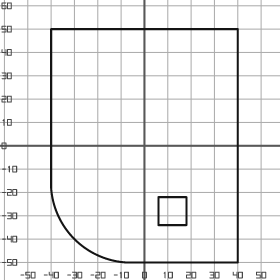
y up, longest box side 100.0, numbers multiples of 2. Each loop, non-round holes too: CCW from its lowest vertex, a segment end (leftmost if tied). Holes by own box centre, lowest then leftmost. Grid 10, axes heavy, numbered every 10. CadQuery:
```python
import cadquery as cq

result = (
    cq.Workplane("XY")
    .moveTo(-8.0, -50.0)
    .lineTo(40.0, -50.0)
    .lineTo(40.0, 50.0)
    .lineTo(-40.0, 50.0)
    .lineTo(-40.0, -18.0)
    .threePointArc((-30.0, -40.0), (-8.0, -50.0))
    .close()
    .moveTo(6.0, -34.0)
    .lineTo(18.0, -34.0)
    .lineTo(18.0, -22.0)
    .lineTo(6.0, -22.0)
    .close()
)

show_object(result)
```